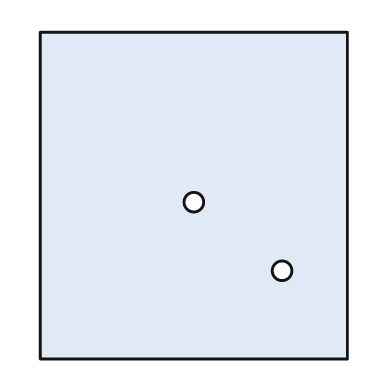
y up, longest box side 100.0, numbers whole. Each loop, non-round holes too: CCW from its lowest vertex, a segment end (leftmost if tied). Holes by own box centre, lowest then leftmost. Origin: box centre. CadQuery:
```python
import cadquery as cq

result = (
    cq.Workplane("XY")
    .moveTo(-47.0, -50.0)
    .lineTo(47.0, -50.0)
    .lineTo(47.0, 50.0)
    .lineTo(-47.0, 50.0)
    .close()
    .moveTo(27.0, -23.0)
    .circle(3.0)
    .moveTo(0.0, -2.0)
    .circle(3.0)
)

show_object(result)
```